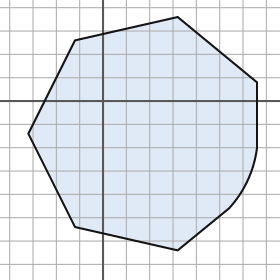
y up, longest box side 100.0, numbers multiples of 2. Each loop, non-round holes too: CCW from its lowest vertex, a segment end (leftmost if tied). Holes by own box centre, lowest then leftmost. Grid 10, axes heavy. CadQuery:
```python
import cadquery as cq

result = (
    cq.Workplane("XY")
    .moveTo(32.0, -64.0)
    .lineTo(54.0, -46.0)
    .threePointArc((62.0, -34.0), (66.0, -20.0))
    .lineTo(66.0, 8.0)
    .lineTo(32.0, 36.0)
    .lineTo(-12.0, 26.0)
    .lineTo(-32.0, -14.0)
    .lineTo(-12.0, -54.0)
    .close()
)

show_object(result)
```